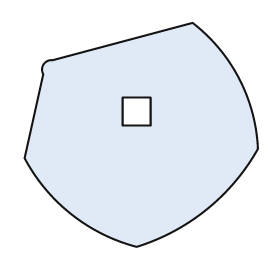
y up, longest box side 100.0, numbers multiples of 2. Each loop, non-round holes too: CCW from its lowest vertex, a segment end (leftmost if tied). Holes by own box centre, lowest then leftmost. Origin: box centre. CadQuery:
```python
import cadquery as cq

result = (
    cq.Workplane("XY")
    .moveTo(-2.0, -48.0)
    .threePointArc((28.0, -32.0), (50.0, -6.0))
    .threePointArc((42.0, 24.0), (22.0, 48.0))
    .lineTo(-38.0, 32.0)
    .threePointArc((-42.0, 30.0), (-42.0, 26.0))
    .lineTo(-50.0, -10.0)
    .threePointArc((-30.0, -34.0), (-2.0, -48.0))
    .close()
    .moveTo(-8.0, 4.0)
    .lineTo(4.0, 4.0)
    .lineTo(4.0, 16.0)
    .lineTo(-8.0, 16.0)
    .close()
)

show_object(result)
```